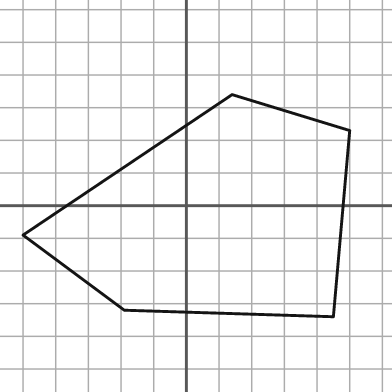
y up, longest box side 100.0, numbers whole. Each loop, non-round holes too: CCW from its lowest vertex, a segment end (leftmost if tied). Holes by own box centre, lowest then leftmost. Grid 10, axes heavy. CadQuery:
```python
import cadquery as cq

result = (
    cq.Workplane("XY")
    .moveTo(45.0, -34.0)
    .lineTo(50.0, 23.0)
    .lineTo(14.0, 34.0)
    .lineTo(-50.0, -9.0)
    .lineTo(-19.0, -32.0)
    .close()
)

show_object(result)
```